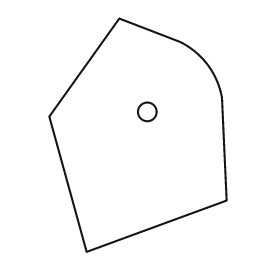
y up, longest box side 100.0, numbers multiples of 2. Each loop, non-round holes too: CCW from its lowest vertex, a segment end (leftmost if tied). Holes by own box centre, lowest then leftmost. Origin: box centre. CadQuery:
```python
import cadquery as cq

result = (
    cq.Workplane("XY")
    .moveTo(-22.0, -50.0)
    .lineTo(38.0, -28.0)
    .lineTo(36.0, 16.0)
    .threePointArc((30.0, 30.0), (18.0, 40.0))
    .lineTo(-8.0, 50.0)
    .lineTo(-38.0, 8.0)
    .close()
    .moveTo(4.0, 10.0)
    .circle(4.0)
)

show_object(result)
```